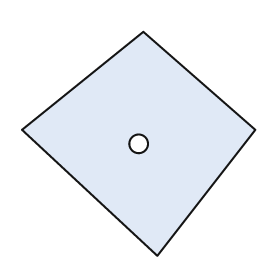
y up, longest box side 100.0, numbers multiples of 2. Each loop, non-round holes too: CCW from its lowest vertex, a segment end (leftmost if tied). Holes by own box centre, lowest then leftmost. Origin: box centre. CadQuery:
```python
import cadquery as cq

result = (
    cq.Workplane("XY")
    .moveTo(8.0, -48.0)
    .lineTo(50.0, 6.0)
    .lineTo(2.0, 48.0)
    .lineTo(-50.0, 6.0)
    .close()
    .moveTo(0.0, 0.0)
    .circle(4.0)
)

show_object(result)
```